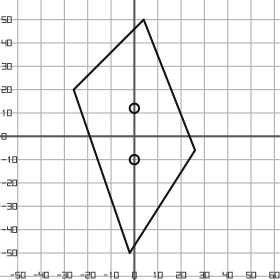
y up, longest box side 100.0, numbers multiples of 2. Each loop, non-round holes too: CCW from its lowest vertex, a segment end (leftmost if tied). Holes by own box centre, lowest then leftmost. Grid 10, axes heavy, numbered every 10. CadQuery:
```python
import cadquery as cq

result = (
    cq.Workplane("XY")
    .moveTo(-2.0, -50.0)
    .lineTo(26.0, -6.0)
    .lineTo(4.0, 50.0)
    .lineTo(-26.0, 20.0)
    .close()
    .moveTo(0.0, -10.0)
    .circle(2.0)
    .moveTo(0.0, 12.0)
    .circle(2.0)
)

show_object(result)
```